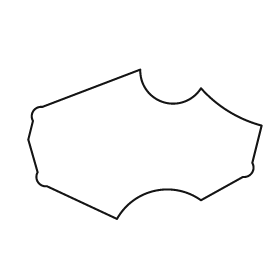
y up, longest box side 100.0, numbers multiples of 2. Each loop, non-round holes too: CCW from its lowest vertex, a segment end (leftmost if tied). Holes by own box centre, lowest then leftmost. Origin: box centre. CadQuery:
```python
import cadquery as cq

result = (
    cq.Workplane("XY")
    .moveTo(-12.0, -32.0)
    .threePointArc((4.0, -20.0), (24.0, -24.0))
    .lineTo(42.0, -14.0)
    .threePointArc((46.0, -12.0), (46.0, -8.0))
    .lineTo(50.0, 8.0)
    .threePointArc((36.0, 14.0), (24.0, 24.0))
    .threePointArc((8.0, 18.0), (-2.0, 32.0))
    .lineTo(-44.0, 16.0)
    .threePointArc((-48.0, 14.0), (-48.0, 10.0))
    .lineTo(-50.0, 2.0)
    .lineTo(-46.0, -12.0)
    .threePointArc((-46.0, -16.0), (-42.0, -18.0))
    .close()
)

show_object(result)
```